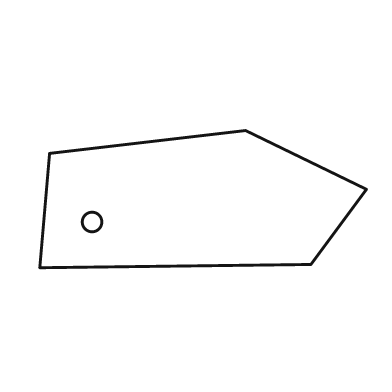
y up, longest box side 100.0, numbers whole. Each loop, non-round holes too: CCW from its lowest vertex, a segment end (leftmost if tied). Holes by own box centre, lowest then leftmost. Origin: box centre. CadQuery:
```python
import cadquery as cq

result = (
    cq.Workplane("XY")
    .moveTo(-50.0, -21.0)
    .lineTo(33.0, -20.0)
    .lineTo(50.0, 3.0)
    .lineTo(13.0, 21.0)
    .lineTo(-47.0, 14.0)
    .close()
    .moveTo(-34.0, -7.0)
    .circle(3.0)
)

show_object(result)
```